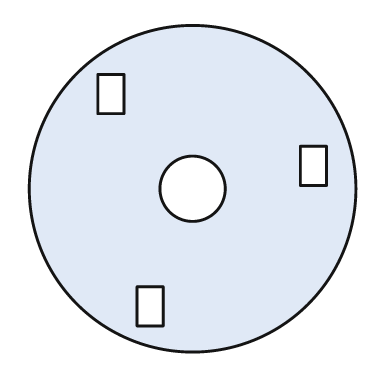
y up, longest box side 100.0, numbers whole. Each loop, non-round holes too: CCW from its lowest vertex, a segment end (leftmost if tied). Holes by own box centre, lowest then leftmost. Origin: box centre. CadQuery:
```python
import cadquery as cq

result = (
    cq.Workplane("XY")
    .moveTo(0.0, 0.0)
    .circle(50.0)
    .moveTo(-17.0, -42.0)
    .lineTo(-9.0, -42.0)
    .lineTo(-9.0, -30.0)
    .lineTo(-17.0, -30.0)
    .close()
    .moveTo(0.0, 0.0)
    .circle(10.0)
    .moveTo(33.0, 1.0)
    .lineTo(41.0, 1.0)
    .lineTo(41.0, 13.0)
    .lineTo(33.0, 13.0)
    .close()
    .moveTo(-29.0, 23.0)
    .lineTo(-21.0, 23.0)
    .lineTo(-21.0, 35.0)
    .lineTo(-29.0, 35.0)
    .close()
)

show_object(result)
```